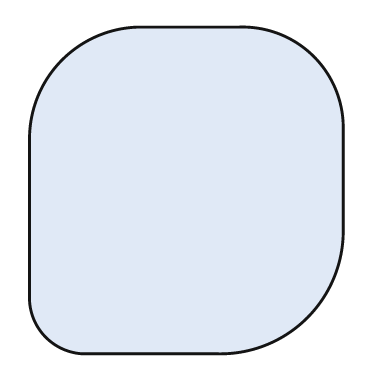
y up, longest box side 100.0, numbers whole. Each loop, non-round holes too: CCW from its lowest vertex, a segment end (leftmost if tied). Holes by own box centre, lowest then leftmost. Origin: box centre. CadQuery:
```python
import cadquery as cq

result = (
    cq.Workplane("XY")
    .moveTo(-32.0, -50.0)
    .lineTo(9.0, -50.0)
    .threePointArc((37.0, -39.0), (48.0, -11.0))
    .lineTo(48.0, 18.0)
    .threePointArc((39.0, 41.0), (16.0, 50.0))
    .lineTo(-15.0, 50.0)
    .threePointArc((-38.0, 40.0), (-48.0, 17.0))
    .lineTo(-48.0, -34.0)
    .threePointArc((-43.0, -45.0), (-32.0, -50.0))
    .close()
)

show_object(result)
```